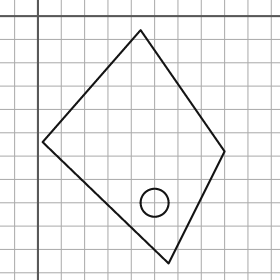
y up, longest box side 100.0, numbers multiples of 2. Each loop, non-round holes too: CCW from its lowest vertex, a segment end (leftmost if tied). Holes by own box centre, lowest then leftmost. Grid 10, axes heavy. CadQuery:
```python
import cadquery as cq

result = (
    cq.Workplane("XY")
    .moveTo(56.0, -106.0)
    .lineTo(80.0, -58.0)
    .lineTo(44.0, -6.0)
    .lineTo(2.0, -54.0)
    .close()
    .moveTo(50.0, -80.0)
    .circle(6.0)
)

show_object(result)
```